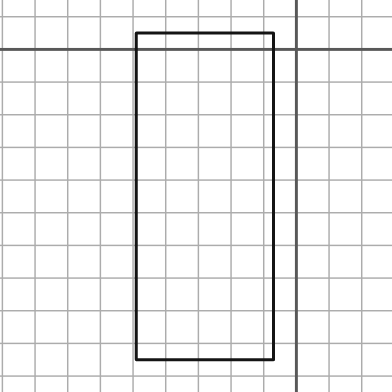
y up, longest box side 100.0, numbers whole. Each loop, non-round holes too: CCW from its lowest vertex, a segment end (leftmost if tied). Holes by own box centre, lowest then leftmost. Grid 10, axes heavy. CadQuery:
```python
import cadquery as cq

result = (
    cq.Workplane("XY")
    .moveTo(-49.0, -95.0)
    .lineTo(-7.0, -95.0)
    .lineTo(-7.0, 5.0)
    .lineTo(-49.0, 5.0)
    .close()
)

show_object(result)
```